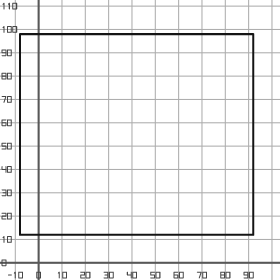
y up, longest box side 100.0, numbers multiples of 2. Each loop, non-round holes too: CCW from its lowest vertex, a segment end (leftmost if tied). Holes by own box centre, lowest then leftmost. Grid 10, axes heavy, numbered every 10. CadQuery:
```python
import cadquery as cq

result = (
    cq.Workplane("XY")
    .moveTo(-8.0, 12.0)
    .lineTo(92.0, 12.0)
    .lineTo(92.0, 98.0)
    .lineTo(-8.0, 98.0)
    .close()
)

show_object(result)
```